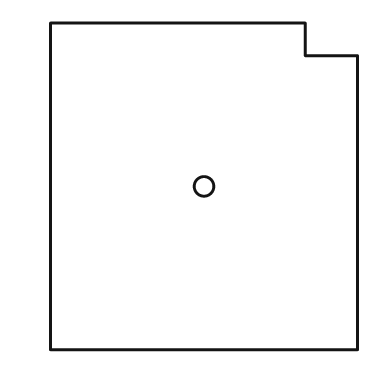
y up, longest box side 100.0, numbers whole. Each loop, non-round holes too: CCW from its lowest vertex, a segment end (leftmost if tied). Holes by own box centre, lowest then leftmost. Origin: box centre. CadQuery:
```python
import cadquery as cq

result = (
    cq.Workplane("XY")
    .moveTo(-47.0, -50.0)
    .lineTo(47.0, -50.0)
    .lineTo(47.0, 40.0)
    .lineTo(31.0, 40.0)
    .lineTo(31.0, 50.0)
    .lineTo(-47.0, 50.0)
    .close()
    .moveTo(0.0, 0.0)
    .circle(3.0)
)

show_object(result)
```